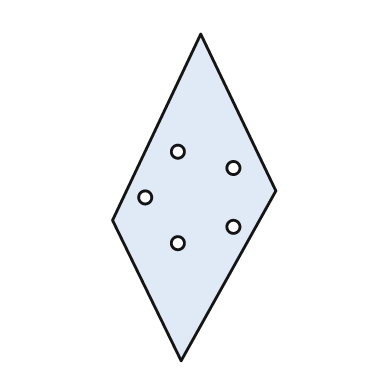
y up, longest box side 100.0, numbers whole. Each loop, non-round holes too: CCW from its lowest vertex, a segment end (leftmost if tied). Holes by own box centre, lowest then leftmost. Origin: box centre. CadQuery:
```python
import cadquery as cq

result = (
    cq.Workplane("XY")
    .moveTo(-4.0, -50.0)
    .lineTo(25.0, 2.0)
    .lineTo(2.0, 50.0)
    .lineTo(-25.0, -7.0)
    .close()
    .moveTo(-5.0, -14.0)
    .circle(2.0)
    .moveTo(12.0, -9.0)
    .circle(2.0)
    .moveTo(-15.0, 0.0)
    .circle(2.0)
    .moveTo(12.0, 9.0)
    .circle(2.0)
    .moveTo(-5.0, 14.0)
    .circle(2.0)
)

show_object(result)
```